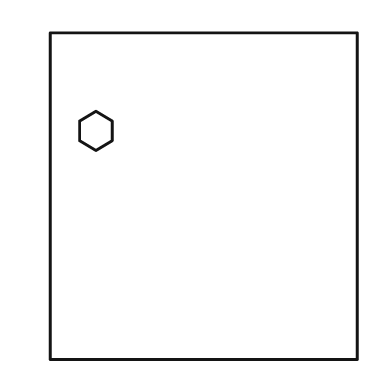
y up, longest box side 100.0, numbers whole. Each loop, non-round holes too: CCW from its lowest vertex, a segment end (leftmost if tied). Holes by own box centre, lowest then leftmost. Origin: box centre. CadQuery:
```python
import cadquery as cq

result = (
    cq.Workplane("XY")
    .moveTo(-47.0, -50.0)
    .lineTo(47.0, -50.0)
    .lineTo(47.0, 50.0)
    .lineTo(-47.0, 50.0)
    .close()
    .moveTo(-33.0, 14.0)
    .lineTo(-28.0, 17.0)
    .lineTo(-28.0, 23.0)
    .lineTo(-33.0, 26.0)
    .lineTo(-38.0, 23.0)
    .lineTo(-38.0, 17.0)
    .close()
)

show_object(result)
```